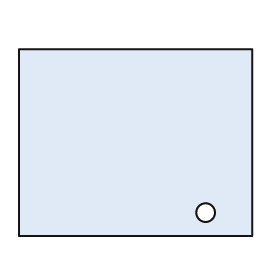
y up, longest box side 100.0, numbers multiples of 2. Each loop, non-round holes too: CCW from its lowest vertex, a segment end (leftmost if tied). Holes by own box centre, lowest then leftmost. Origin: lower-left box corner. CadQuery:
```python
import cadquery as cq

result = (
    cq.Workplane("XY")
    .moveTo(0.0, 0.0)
    .lineTo(100.0, 0.0)
    .lineTo(100.0, 80.0)
    .lineTo(0.0, 80.0)
    .close()
    .moveTo(80.0, 10.0)
    .circle(4.0)
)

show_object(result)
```